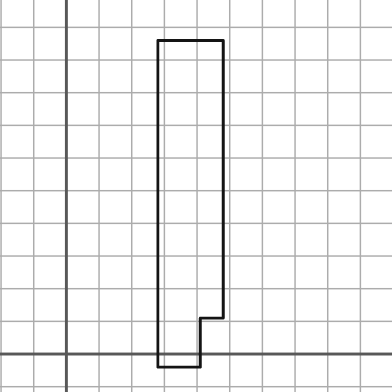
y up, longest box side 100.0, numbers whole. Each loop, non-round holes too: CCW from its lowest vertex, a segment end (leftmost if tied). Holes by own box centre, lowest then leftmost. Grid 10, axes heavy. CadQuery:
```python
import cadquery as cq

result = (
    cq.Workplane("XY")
    .moveTo(28.0, -4.0)
    .lineTo(41.0, -4.0)
    .lineTo(41.0, 11.0)
    .lineTo(48.0, 11.0)
    .lineTo(48.0, 96.0)
    .lineTo(28.0, 96.0)
    .close()
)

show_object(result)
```